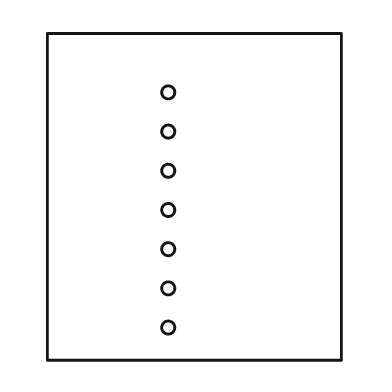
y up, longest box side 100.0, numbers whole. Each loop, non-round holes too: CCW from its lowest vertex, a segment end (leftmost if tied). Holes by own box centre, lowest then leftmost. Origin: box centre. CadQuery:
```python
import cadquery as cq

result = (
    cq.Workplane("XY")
    .moveTo(-45.0, -50.0)
    .lineTo(45.0, -50.0)
    .lineTo(45.0, 50.0)
    .lineTo(-45.0, 50.0)
    .close()
    .moveTo(-8.0, -40.0)
    .circle(2.0)
    .moveTo(-8.0, -28.0)
    .circle(2.0)
    .moveTo(-8.0, -16.0)
    .circle(2.0)
    .moveTo(-8.0, -4.0)
    .circle(2.0)
    .moveTo(-8.0, 8.0)
    .circle(2.0)
    .moveTo(-8.0, 20.0)
    .circle(2.0)
    .moveTo(-8.0, 32.0)
    .circle(2.0)
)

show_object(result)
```